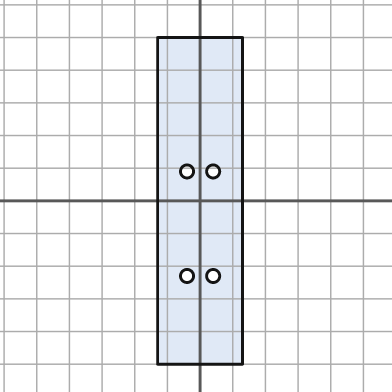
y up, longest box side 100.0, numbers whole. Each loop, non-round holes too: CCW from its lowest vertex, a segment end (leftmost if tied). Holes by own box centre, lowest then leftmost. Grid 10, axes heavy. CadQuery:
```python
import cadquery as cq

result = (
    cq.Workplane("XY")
    .moveTo(-13.0, -50.0)
    .lineTo(13.0, -50.0)
    .lineTo(13.0, 50.0)
    .lineTo(-13.0, 50.0)
    .close()
    .moveTo(-4.0, -23.0)
    .circle(2.0)
    .moveTo(4.0, -23.0)
    .circle(2.0)
    .moveTo(-4.0, 9.0)
    .circle(2.0)
    .moveTo(4.0, 9.0)
    .circle(2.0)
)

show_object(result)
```